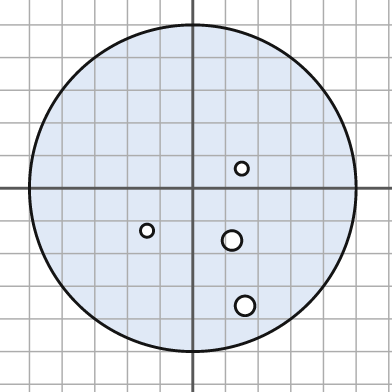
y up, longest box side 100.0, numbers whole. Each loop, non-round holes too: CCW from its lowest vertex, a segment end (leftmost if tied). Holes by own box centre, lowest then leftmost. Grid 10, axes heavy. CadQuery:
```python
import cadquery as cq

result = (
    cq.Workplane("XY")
    .moveTo(0.0, 0.0)
    .circle(50.0)
    .moveTo(16.0, -36.0)
    .circle(3.0)
    .moveTo(12.0, -16.0)
    .circle(3.0)
    .moveTo(-14.0, -13.0)
    .circle(2.0)
    .moveTo(15.0, 6.0)
    .circle(2.0)
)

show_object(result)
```